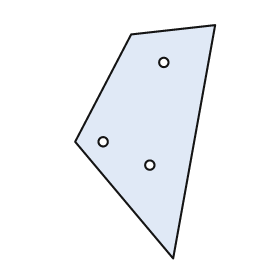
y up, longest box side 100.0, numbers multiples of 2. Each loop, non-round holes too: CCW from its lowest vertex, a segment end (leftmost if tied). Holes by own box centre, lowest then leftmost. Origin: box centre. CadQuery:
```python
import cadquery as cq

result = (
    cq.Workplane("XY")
    .moveTo(12.0, -50.0)
    .lineTo(30.0, 50.0)
    .lineTo(-6.0, 46.0)
    .lineTo(-30.0, 0.0)
    .close()
    .moveTo(2.0, -10.0)
    .circle(2.0)
    .moveTo(-18.0, 0.0)
    .circle(2.0)
    .moveTo(8.0, 34.0)
    .circle(2.0)
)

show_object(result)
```